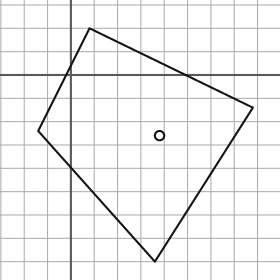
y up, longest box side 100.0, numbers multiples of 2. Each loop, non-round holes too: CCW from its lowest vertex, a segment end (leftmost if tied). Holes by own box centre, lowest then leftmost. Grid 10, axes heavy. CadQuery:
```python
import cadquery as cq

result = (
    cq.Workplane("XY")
    .moveTo(36.0, -80.0)
    .lineTo(78.0, -14.0)
    .lineTo(8.0, 20.0)
    .lineTo(-14.0, -24.0)
    .close()
    .moveTo(38.0, -26.0)
    .circle(2.0)
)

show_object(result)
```